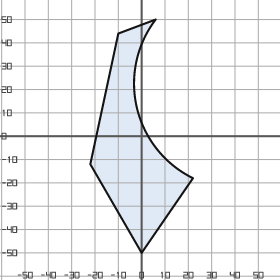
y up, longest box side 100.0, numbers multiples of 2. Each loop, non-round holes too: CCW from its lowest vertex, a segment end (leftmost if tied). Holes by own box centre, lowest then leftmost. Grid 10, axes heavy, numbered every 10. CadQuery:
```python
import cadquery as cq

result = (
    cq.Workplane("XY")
    .moveTo(0.0, -50.0)
    .lineTo(22.0, -18.0)
    .threePointArc((-2.0, 12.0), (6.0, 50.0))
    .lineTo(-10.0, 44.0)
    .lineTo(-22.0, -12.0)
    .close()
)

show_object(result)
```